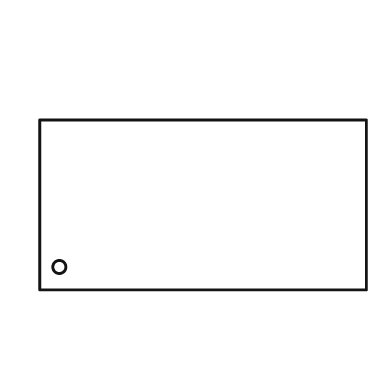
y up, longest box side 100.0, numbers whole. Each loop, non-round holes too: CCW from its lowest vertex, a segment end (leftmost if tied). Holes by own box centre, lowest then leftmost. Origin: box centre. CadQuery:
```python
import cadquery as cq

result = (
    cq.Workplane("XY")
    .moveTo(-50.0, -26.0)
    .lineTo(50.0, -26.0)
    .lineTo(50.0, 26.0)
    .lineTo(-50.0, 26.0)
    .close()
    .moveTo(-44.0, -19.0)
    .circle(2.0)
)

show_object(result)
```